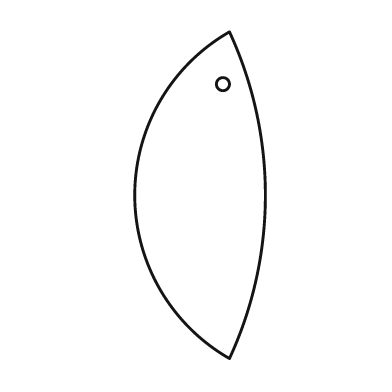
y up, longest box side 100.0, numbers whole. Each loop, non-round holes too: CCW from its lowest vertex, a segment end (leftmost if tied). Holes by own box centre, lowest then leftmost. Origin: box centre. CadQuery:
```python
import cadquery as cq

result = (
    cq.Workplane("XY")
    .moveTo(9.0, -50.0)
    .threePointArc((20.0, 0.0), (9.0, 50.0))
    .threePointArc((-20.0, 0.0), (9.0, -50.0))
    .close()
    .moveTo(7.0, 34.0)
    .circle(2.0)
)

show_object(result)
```